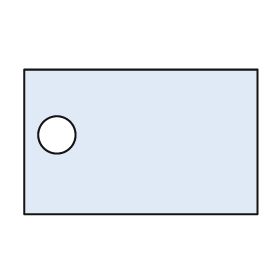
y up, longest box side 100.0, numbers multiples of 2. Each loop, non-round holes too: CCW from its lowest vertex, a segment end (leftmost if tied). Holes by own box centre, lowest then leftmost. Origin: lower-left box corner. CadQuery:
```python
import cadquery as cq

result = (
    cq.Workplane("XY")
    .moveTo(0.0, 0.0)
    .lineTo(100.0, 0.0)
    .lineTo(100.0, 62.0)
    .lineTo(0.0, 62.0)
    .close()
    .moveTo(14.0, 34.0)
    .circle(8.0)
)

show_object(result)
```